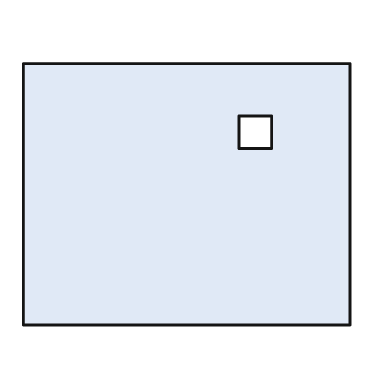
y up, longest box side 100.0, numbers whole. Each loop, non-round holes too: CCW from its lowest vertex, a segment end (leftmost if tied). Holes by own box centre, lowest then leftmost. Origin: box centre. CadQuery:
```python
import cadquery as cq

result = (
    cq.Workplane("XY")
    .moveTo(-50.0, -40.0)
    .lineTo(50.0, -40.0)
    .lineTo(50.0, 40.0)
    .lineTo(-50.0, 40.0)
    .close()
    .moveTo(16.0, 14.0)
    .lineTo(26.0, 14.0)
    .lineTo(26.0, 24.0)
    .lineTo(16.0, 24.0)
    .close()
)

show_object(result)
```